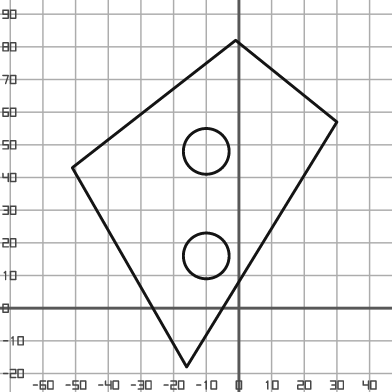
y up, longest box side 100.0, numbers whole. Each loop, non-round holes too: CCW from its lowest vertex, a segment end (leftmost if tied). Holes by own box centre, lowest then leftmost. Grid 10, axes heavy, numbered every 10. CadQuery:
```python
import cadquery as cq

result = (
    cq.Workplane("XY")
    .moveTo(-16.0, -18.0)
    .lineTo(30.0, 57.0)
    .lineTo(-1.0, 82.0)
    .lineTo(-51.0, 43.0)
    .close()
    .moveTo(-10.0, 16.0)
    .circle(7.0)
    .moveTo(-10.0, 48.0)
    .circle(7.0)
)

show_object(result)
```